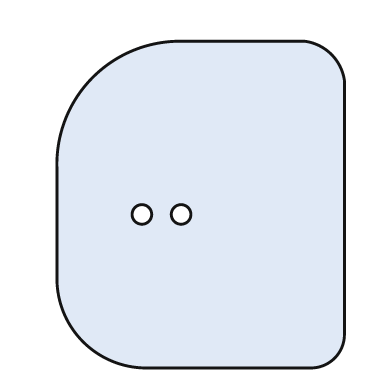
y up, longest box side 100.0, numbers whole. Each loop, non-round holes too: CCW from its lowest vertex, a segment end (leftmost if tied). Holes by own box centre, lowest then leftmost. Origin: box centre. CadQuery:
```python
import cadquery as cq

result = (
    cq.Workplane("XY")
    .moveTo(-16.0, -50.0)
    .lineTo(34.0, -50.0)
    .threePointArc((41.0, -47.0), (44.0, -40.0))
    .lineTo(44.0, 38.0)
    .threePointArc((40.0, 46.0), (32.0, 50.0))
    .lineTo(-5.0, 50.0)
    .threePointArc((-33.0, 39.0), (-44.0, 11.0))
    .lineTo(-44.0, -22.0)
    .threePointArc((-36.0, -42.0), (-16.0, -50.0))
    .close()
    .moveTo(-18.0, -3.0)
    .circle(3.0)
    .moveTo(-6.0, -3.0)
    .circle(3.0)
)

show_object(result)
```